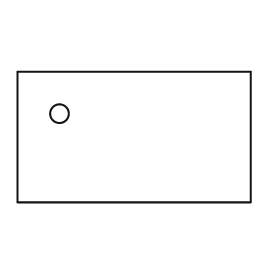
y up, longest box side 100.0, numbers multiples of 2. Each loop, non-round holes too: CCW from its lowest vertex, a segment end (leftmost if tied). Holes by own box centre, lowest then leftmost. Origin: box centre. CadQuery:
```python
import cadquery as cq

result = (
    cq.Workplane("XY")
    .moveTo(-50.0, -28.0)
    .lineTo(50.0, -28.0)
    .lineTo(50.0, 28.0)
    .lineTo(-50.0, 28.0)
    .close()
    .moveTo(-32.0, 10.0)
    .circle(4.0)
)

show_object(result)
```